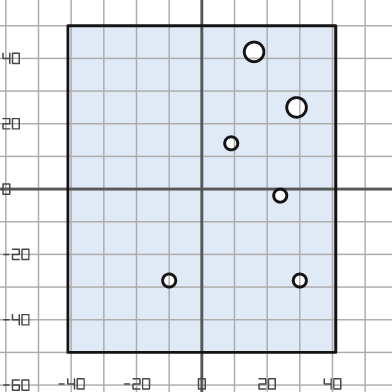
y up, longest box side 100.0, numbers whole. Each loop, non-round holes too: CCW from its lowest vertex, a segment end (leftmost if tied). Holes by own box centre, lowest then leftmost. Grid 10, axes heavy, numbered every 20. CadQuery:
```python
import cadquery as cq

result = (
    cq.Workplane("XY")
    .moveTo(-41.0, -50.0)
    .lineTo(41.0, -50.0)
    .lineTo(41.0, 50.0)
    .lineTo(-41.0, 50.0)
    .close()
    .moveTo(-10.0, -28.0)
    .circle(2.0)
    .moveTo(30.0, -28.0)
    .circle(2.0)
    .moveTo(24.0, -2.0)
    .circle(2.0)
    .moveTo(9.0, 14.0)
    .circle(2.0)
    .moveTo(29.0, 25.0)
    .circle(3.0)
    .moveTo(16.0, 42.0)
    .circle(3.0)
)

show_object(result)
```